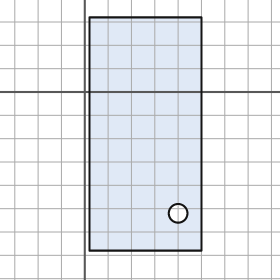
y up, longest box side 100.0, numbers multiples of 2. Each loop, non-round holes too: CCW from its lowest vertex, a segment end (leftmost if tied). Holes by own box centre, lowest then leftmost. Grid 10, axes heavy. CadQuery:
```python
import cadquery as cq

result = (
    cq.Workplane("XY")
    .moveTo(2.0, -68.0)
    .lineTo(50.0, -68.0)
    .lineTo(50.0, 32.0)
    .lineTo(2.0, 32.0)
    .close()
    .moveTo(40.0, -52.0)
    .circle(4.0)
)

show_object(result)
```